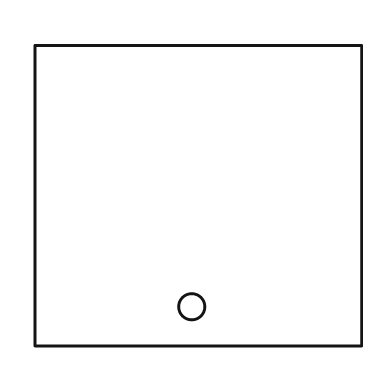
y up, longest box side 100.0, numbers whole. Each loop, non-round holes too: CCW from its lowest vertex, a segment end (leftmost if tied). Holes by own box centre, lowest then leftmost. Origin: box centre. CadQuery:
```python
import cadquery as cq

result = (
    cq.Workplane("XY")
    .moveTo(-50.0, -46.0)
    .lineTo(50.0, -46.0)
    .lineTo(50.0, 46.0)
    .lineTo(-50.0, 46.0)
    .close()
    .moveTo(-2.0, -34.0)
    .circle(4.0)
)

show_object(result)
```